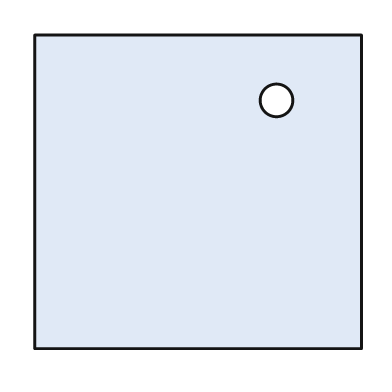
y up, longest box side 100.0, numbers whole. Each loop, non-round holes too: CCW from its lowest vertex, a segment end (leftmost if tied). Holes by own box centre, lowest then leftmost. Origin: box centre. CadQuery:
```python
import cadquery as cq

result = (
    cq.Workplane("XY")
    .moveTo(-50.0, -48.0)
    .lineTo(50.0, -48.0)
    .lineTo(50.0, 48.0)
    .lineTo(-50.0, 48.0)
    .close()
    .moveTo(24.0, 28.0)
    .circle(5.0)
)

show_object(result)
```